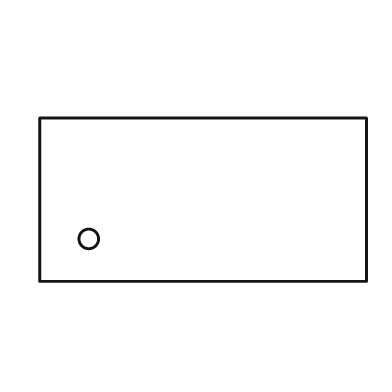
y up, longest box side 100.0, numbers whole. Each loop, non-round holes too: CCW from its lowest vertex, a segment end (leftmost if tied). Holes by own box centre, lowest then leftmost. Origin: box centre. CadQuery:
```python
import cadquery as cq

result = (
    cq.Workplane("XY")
    .moveTo(-50.0, -25.0)
    .lineTo(50.0, -25.0)
    .lineTo(50.0, 25.0)
    .lineTo(-50.0, 25.0)
    .close()
    .moveTo(-35.0, -12.0)
    .circle(3.0)
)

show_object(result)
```